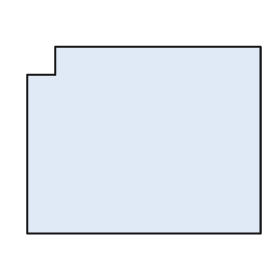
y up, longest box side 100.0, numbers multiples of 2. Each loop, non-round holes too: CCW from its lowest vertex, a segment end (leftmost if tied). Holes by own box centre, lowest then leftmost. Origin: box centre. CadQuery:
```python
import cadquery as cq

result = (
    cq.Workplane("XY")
    .moveTo(-50.0, -40.0)
    .lineTo(50.0, -40.0)
    .lineTo(50.0, 40.0)
    .lineTo(-38.0, 40.0)
    .lineTo(-38.0, 28.0)
    .lineTo(-50.0, 28.0)
    .close()
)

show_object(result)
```